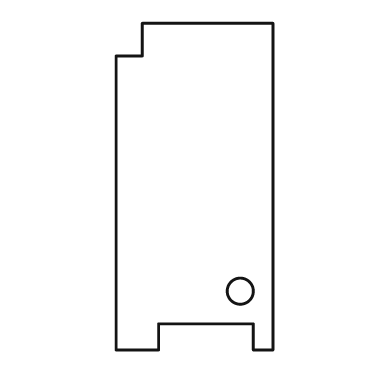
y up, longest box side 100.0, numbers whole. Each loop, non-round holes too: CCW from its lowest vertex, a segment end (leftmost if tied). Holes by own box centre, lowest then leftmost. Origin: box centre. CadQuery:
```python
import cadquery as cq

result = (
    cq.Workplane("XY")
    .moveTo(-24.0, -50.0)
    .lineTo(-11.0, -50.0)
    .lineTo(-11.0, -42.0)
    .lineTo(18.0, -42.0)
    .lineTo(18.0, -50.0)
    .lineTo(24.0, -50.0)
    .lineTo(24.0, 50.0)
    .lineTo(-16.0, 50.0)
    .lineTo(-16.0, 40.0)
    .lineTo(-24.0, 40.0)
    .close()
    .moveTo(14.0, -32.0)
    .circle(4.0)
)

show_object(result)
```